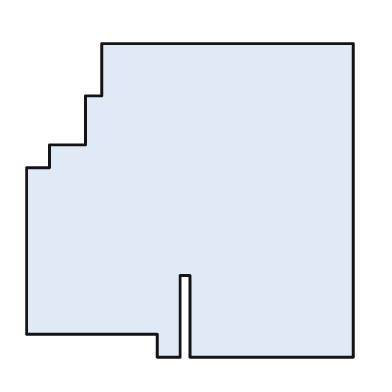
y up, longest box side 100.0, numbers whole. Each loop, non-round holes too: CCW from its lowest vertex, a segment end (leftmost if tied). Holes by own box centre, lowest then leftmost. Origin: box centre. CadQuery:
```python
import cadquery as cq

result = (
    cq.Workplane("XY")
    .moveTo(-10.0, -48.0)
    .lineTo(-3.0, -48.0)
    .lineTo(-3.0, -23.0)
    .lineTo(0.0, -23.0)
    .lineTo(0.0, -48.0)
    .lineTo(50.0, -48.0)
    .lineTo(50.0, 48.0)
    .lineTo(-27.0, 48.0)
    .lineTo(-27.0, 32.0)
    .lineTo(-32.0, 32.0)
    .lineTo(-32.0, 17.0)
    .lineTo(-43.0, 17.0)
    .lineTo(-43.0, 10.0)
    .lineTo(-50.0, 10.0)
    .lineTo(-50.0, -41.0)
    .lineTo(-10.0, -41.0)
    .close()
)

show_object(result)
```